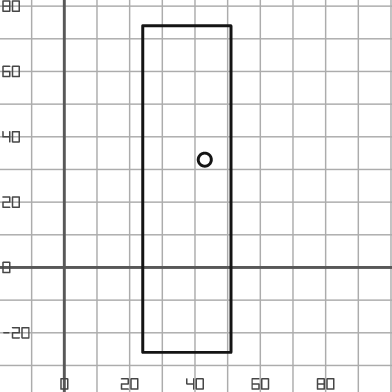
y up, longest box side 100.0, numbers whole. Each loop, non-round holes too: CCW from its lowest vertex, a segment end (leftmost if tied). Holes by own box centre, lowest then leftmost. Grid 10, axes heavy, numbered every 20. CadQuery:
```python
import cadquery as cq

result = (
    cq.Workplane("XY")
    .moveTo(24.0, -26.0)
    .lineTo(51.0, -26.0)
    .lineTo(51.0, 74.0)
    .lineTo(24.0, 74.0)
    .close()
    .moveTo(43.0, 33.0)
    .circle(2.0)
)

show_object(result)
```